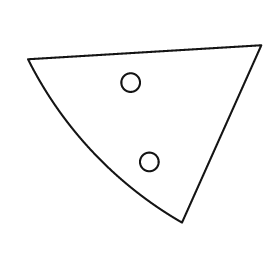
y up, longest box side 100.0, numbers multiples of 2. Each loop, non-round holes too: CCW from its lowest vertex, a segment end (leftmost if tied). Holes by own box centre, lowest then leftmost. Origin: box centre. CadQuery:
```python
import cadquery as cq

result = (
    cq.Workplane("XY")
    .moveTo(16.0, -38.0)
    .lineTo(50.0, 38.0)
    .lineTo(-50.0, 32.0)
    .threePointArc((-22.0, -8.0), (16.0, -38.0))
    .close()
    .moveTo(2.0, -12.0)
    .circle(4.0)
    .moveTo(-6.0, 22.0)
    .circle(4.0)
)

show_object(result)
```